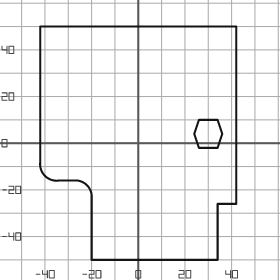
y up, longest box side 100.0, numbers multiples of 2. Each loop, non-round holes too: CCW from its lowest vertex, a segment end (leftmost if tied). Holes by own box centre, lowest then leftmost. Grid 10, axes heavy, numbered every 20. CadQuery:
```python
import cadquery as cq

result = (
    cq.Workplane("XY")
    .moveTo(-20.0, -50.0)
    .lineTo(34.0, -50.0)
    .lineTo(34.0, -26.0)
    .lineTo(42.0, -26.0)
    .lineTo(42.0, 50.0)
    .lineTo(-42.0, 50.0)
    .lineTo(-42.0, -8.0)
    .threePointArc((-40.0, -14.0), (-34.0, -16.0))
    .lineTo(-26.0, -16.0)
    .threePointArc((-22.0, -18.0), (-20.0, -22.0))
    .close()
    .moveTo(26.0, -2.0)
    .lineTo(34.0, -2.0)
    .lineTo(36.0, 4.0)
    .lineTo(34.0, 10.0)
    .lineTo(26.0, 10.0)
    .lineTo(24.0, 4.0)
    .close()
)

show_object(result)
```